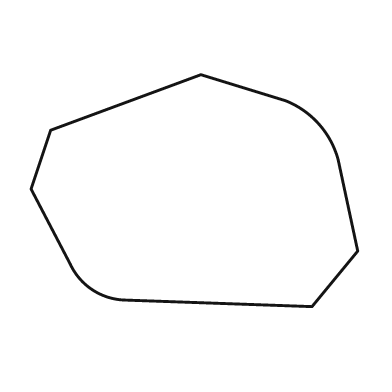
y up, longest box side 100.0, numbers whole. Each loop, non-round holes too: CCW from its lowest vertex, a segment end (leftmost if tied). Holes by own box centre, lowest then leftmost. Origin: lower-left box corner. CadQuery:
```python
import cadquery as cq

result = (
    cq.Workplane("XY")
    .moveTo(86.0, 0.0)
    .lineTo(100.0, 17.0)
    .lineTo(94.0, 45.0)
    .threePointArc((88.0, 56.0), (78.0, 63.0))
    .lineTo(52.0, 71.0)
    .lineTo(6.0, 54.0)
    .lineTo(0.0, 36.0)
    .lineTo(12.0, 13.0)
    .threePointArc((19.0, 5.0), (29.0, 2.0))
    .close()
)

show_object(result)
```